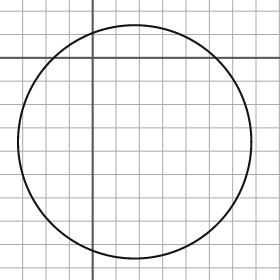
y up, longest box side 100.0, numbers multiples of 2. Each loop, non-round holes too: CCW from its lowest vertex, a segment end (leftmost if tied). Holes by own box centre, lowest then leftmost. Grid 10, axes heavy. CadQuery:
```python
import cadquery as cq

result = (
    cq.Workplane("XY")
    .moveTo(18.0, -36.0)
    .circle(50.0)
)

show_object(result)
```